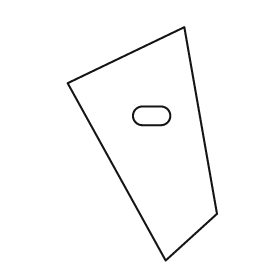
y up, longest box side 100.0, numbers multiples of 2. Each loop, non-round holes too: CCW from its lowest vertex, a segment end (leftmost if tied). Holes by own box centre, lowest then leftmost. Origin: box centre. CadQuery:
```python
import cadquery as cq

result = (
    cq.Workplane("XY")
    .moveTo(10.0, -50.0)
    .lineTo(32.0, -30.0)
    .lineTo(18.0, 50.0)
    .lineTo(-32.0, 26.0)
    .close()
    .moveTo(0.0, 8.0)
    .lineTo(8.0, 8.0)
    .threePointArc((12.0, 12.0), (8.0, 16.0))
    .lineTo(0.0, 16.0)
    .threePointArc((-4.0, 12.0), (0.0, 8.0))
    .close()
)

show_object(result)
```